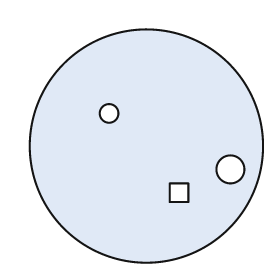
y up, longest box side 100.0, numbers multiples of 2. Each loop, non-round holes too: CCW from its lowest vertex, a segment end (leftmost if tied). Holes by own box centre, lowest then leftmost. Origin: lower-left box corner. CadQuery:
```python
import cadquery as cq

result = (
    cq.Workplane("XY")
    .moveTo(50.0, 50.0)
    .circle(50.0)
    .moveTo(60.0, 26.0)
    .lineTo(68.0, 26.0)
    .lineTo(68.0, 34.0)
    .lineTo(60.0, 34.0)
    .close()
    .moveTo(86.0, 40.0)
    .circle(6.0)
    .moveTo(34.0, 64.0)
    .circle(4.0)
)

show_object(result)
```